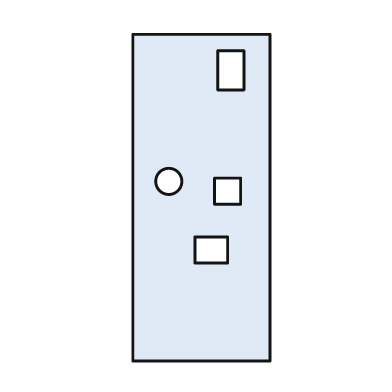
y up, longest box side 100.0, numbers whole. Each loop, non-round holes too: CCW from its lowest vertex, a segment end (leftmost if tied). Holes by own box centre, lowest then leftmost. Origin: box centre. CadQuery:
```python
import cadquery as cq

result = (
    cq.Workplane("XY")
    .moveTo(-21.0, -50.0)
    .lineTo(21.0, -50.0)
    .lineTo(21.0, 50.0)
    .lineTo(-21.0, 50.0)
    .close()
    .moveTo(-2.0, -20.0)
    .lineTo(8.0, -20.0)
    .lineTo(8.0, -12.0)
    .lineTo(-2.0, -12.0)
    .close()
    .moveTo(4.0, -2.0)
    .lineTo(12.0, -2.0)
    .lineTo(12.0, 6.0)
    .lineTo(4.0, 6.0)
    .close()
    .moveTo(-10.0, 5.0)
    .circle(4.0)
    .moveTo(5.0, 33.0)
    .lineTo(13.0, 33.0)
    .lineTo(13.0, 45.0)
    .lineTo(5.0, 45.0)
    .close()
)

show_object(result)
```